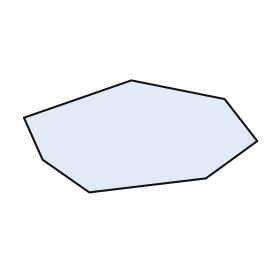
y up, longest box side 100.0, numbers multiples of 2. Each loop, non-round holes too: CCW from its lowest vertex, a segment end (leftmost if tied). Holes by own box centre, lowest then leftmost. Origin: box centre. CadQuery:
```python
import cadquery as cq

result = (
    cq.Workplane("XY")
    .moveTo(-22.0, -24.0)
    .lineTo(28.0, -18.0)
    .lineTo(50.0, -2.0)
    .lineTo(36.0, 16.0)
    .lineTo(-4.0, 24.0)
    .lineTo(-50.0, 8.0)
    .lineTo(-42.0, -10.0)
    .close()
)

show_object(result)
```